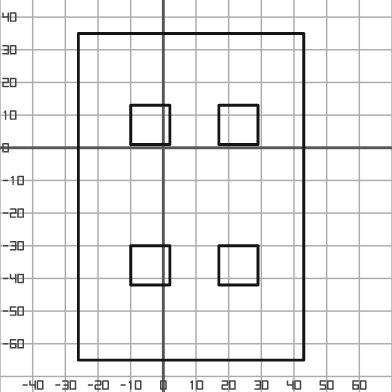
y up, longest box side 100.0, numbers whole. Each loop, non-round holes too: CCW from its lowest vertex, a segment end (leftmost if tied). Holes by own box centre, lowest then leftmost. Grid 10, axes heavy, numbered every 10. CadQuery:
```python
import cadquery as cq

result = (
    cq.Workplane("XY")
    .moveTo(-26.0, -65.0)
    .lineTo(43.0, -65.0)
    .lineTo(43.0, 35.0)
    .lineTo(-26.0, 35.0)
    .close()
    .moveTo(-10.0, -42.0)
    .lineTo(2.0, -42.0)
    .lineTo(2.0, -30.0)
    .lineTo(-10.0, -30.0)
    .close()
    .moveTo(17.0, -42.0)
    .lineTo(29.0, -42.0)
    .lineTo(29.0, -30.0)
    .lineTo(17.0, -30.0)
    .close()
    .moveTo(-10.0, 1.0)
    .lineTo(2.0, 1.0)
    .lineTo(2.0, 13.0)
    .lineTo(-10.0, 13.0)
    .close()
    .moveTo(17.0, 1.0)
    .lineTo(29.0, 1.0)
    .lineTo(29.0, 13.0)
    .lineTo(17.0, 13.0)
    .close()
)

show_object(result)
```